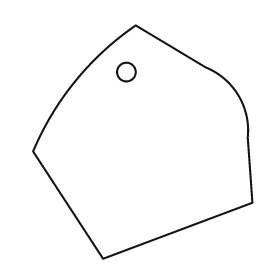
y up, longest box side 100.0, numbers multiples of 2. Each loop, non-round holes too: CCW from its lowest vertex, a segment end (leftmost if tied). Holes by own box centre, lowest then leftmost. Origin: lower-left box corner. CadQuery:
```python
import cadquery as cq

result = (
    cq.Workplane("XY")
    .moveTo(30.0, 0.0)
    .lineTo(94.0, 24.0)
    .lineTo(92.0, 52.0)
    .threePointArc((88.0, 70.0), (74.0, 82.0))
    .lineTo(44.0, 100.0)
    .threePointArc((18.0, 76.0), (0.0, 46.0))
    .close()
    .moveTo(40.0, 80.0)
    .circle(4.0)
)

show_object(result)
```